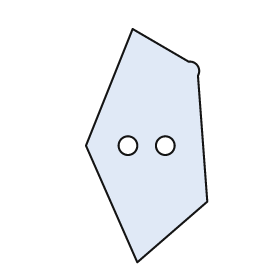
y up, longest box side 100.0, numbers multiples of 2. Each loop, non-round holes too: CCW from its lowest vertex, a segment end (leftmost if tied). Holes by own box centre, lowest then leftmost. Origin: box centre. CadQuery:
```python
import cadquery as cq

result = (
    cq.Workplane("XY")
    .moveTo(-4.0, -50.0)
    .lineTo(26.0, -24.0)
    .lineTo(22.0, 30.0)
    .threePointArc((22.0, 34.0), (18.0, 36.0))
    .lineTo(-6.0, 50.0)
    .lineTo(-26.0, 0.0)
    .close()
    .moveTo(-8.0, 0.0)
    .circle(4.0)
    .moveTo(8.0, 0.0)
    .circle(4.0)
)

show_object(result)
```